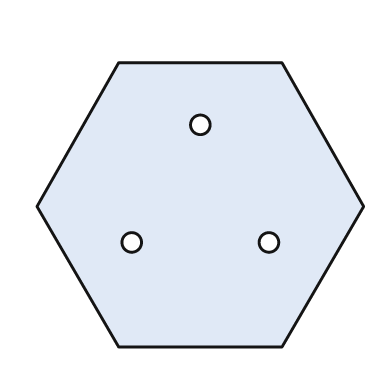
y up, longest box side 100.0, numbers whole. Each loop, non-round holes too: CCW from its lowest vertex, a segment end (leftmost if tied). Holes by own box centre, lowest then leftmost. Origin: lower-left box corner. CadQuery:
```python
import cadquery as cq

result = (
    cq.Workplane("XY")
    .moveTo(25.0, 0.0)
    .lineTo(75.0, 0.0)
    .lineTo(100.0, 43.0)
    .lineTo(75.0, 87.0)
    .lineTo(25.0, 87.0)
    .lineTo(0.0, 43.0)
    .close()
    .moveTo(29.0, 32.0)
    .circle(3.0)
    .moveTo(71.0, 32.0)
    .circle(3.0)
    .moveTo(50.0, 68.0)
    .circle(3.0)
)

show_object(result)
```